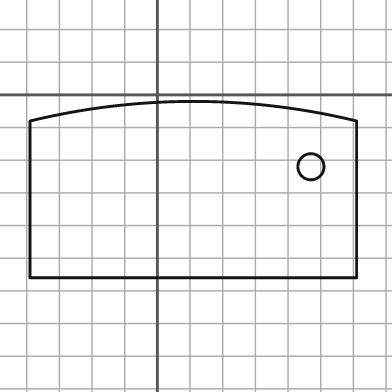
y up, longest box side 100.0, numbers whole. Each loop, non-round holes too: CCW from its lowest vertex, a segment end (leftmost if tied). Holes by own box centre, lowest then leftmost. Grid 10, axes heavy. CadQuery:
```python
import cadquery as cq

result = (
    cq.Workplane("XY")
    .moveTo(-39.0, -56.0)
    .lineTo(61.0, -56.0)
    .lineTo(61.0, -8.0)
    .threePointArc((11.0, -2.0), (-39.0, -8.0))
    .close()
    .moveTo(47.0, -22.0)
    .circle(4.0)
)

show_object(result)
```